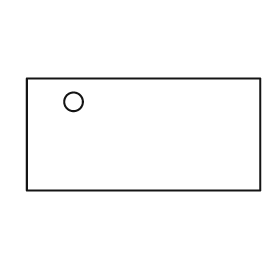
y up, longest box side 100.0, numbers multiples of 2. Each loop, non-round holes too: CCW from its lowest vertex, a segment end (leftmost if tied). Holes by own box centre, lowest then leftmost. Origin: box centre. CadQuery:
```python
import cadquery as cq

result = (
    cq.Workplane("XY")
    .moveTo(-50.0, -24.0)
    .lineTo(50.0, -24.0)
    .lineTo(50.0, 24.0)
    .lineTo(-50.0, 24.0)
    .close()
    .moveTo(-30.0, 14.0)
    .circle(4.0)
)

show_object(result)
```